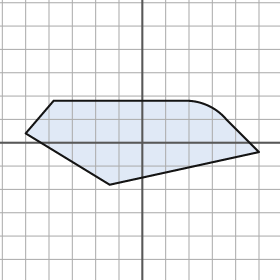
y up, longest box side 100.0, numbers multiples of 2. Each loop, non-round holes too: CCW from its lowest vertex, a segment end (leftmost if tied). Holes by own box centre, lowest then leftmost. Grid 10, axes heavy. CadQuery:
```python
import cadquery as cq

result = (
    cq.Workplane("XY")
    .moveTo(-14.0, -18.0)
    .lineTo(50.0, -4.0)
    .lineTo(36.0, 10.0)
    .threePointArc((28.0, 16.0), (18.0, 18.0))
    .lineTo(-38.0, 18.0)
    .lineTo(-50.0, 4.0)
    .close()
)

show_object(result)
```